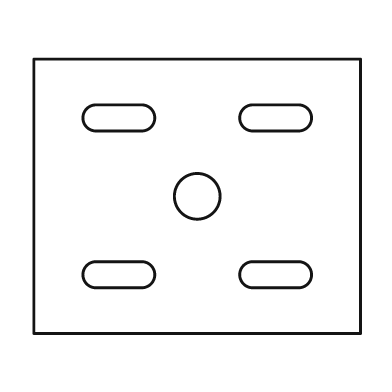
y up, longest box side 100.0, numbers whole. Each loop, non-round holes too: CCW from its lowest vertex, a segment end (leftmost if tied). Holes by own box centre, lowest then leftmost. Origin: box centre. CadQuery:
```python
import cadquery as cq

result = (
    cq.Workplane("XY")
    .moveTo(-50.0, -42.0)
    .lineTo(50.0, -42.0)
    .lineTo(50.0, 42.0)
    .lineTo(-50.0, 42.0)
    .close()
    .moveTo(-31.0, -28.0)
    .lineTo(-17.0, -28.0)
    .threePointArc((-13.0, -24.0), (-17.0, -20.0))
    .lineTo(-31.0, -20.0)
    .threePointArc((-35.0, -24.0), (-31.0, -28.0))
    .close()
    .moveTo(17.0, -28.0)
    .lineTo(31.0, -28.0)
    .threePointArc((35.0, -24.0), (31.0, -20.0))
    .lineTo(17.0, -20.0)
    .threePointArc((13.0, -24.0), (17.0, -28.0))
    .close()
    .moveTo(0.0, 0.0)
    .circle(7.0)
    .moveTo(-31.0, 20.0)
    .lineTo(-17.0, 20.0)
    .threePointArc((-13.0, 24.0), (-17.0, 28.0))
    .lineTo(-31.0, 28.0)
    .threePointArc((-35.0, 24.0), (-31.0, 20.0))
    .close()
    .moveTo(17.0, 20.0)
    .lineTo(31.0, 20.0)
    .threePointArc((35.0, 24.0), (31.0, 28.0))
    .lineTo(17.0, 28.0)
    .threePointArc((13.0, 24.0), (17.0, 20.0))
    .close()
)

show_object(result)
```